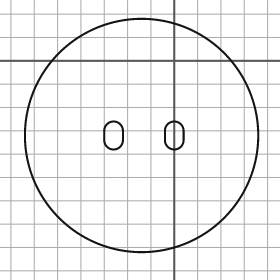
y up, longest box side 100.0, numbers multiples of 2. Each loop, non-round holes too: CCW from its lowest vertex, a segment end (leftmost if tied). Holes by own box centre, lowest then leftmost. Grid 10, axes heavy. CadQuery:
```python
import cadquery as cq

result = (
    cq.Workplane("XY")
    .moveTo(-14.0, -32.0)
    .circle(50.0)
    .moveTo(-30.0, -34.0)
    .threePointArc((-26.0, -38.0), (-22.0, -34.0))
    .lineTo(-22.0, -30.0)
    .threePointArc((-26.0, -26.0), (-30.0, -30.0))
    .close()
    .moveTo(-4.0, -34.0)
    .threePointArc((0.0, -38.0), (4.0, -34.0))
    .lineTo(4.0, -30.0)
    .threePointArc((0.0, -26.0), (-4.0, -30.0))
    .close()
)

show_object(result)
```